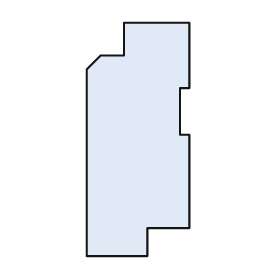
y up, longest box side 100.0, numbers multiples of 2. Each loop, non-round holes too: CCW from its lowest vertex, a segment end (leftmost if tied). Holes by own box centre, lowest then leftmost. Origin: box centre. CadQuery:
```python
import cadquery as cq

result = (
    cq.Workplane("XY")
    .moveTo(-22.0, -50.0)
    .lineTo(4.0, -50.0)
    .lineTo(4.0, -38.0)
    .lineTo(22.0, -38.0)
    .lineTo(22.0, 2.0)
    .lineTo(18.0, 2.0)
    .lineTo(18.0, 22.0)
    .lineTo(22.0, 22.0)
    .lineTo(22.0, 50.0)
    .lineTo(-6.0, 50.0)
    .lineTo(-6.0, 36.0)
    .lineTo(-16.0, 36.0)
    .lineTo(-22.0, 30.0)
    .close()
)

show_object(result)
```